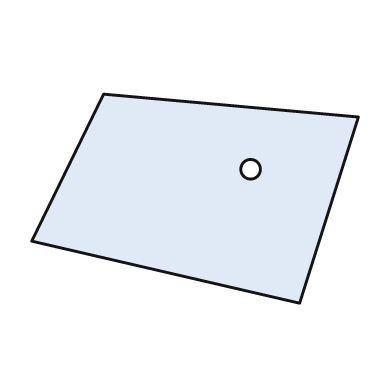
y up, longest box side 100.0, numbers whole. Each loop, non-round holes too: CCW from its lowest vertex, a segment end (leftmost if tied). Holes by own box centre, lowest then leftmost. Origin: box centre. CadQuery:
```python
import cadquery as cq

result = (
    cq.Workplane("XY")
    .moveTo(32.0, -32.0)
    .lineTo(50.0, 25.0)
    .lineTo(-28.0, 32.0)
    .lineTo(-50.0, -13.0)
    .close()
    .moveTo(17.0, 9.0)
    .circle(3.0)
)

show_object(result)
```